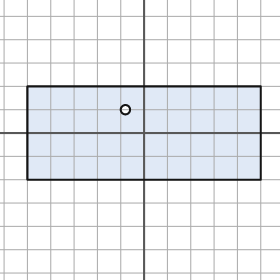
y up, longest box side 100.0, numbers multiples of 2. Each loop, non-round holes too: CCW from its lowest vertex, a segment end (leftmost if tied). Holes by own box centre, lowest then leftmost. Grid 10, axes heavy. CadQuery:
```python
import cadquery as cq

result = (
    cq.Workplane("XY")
    .moveTo(-50.0, -20.0)
    .lineTo(50.0, -20.0)
    .lineTo(50.0, 20.0)
    .lineTo(-50.0, 20.0)
    .close()
    .moveTo(-8.0, 10.0)
    .circle(2.0)
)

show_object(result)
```